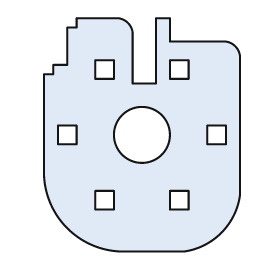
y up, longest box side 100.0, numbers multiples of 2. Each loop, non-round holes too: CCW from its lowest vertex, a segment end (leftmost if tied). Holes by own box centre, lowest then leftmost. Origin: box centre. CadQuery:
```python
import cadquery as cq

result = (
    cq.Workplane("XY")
    .moveTo(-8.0, -50.0)
    .lineTo(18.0, -50.0)
    .threePointArc((34.0, -42.0), (42.0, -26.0))
    .lineTo(42.0, 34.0)
    .threePointArc((40.0, 38.0), (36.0, 40.0))
    .lineTo(12.0, 40.0)
    .lineTo(12.0, 50.0)
    .lineTo(6.0, 50.0)
    .lineTo(6.0, 22.0)
    .lineTo(-4.0, 22.0)
    .lineTo(-4.0, 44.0)
    .threePointArc((-6.0, 48.0), (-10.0, 50.0))
    .lineTo(-28.0, 50.0)
    .lineTo(-28.0, 46.0)
    .lineTo(-32.0, 46.0)
    .lineTo(-32.0, 30.0)
    .lineTo(-38.0, 30.0)
    .lineTo(-38.0, 26.0)
    .lineTo(-42.0, 26.0)
    .lineTo(-42.0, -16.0)
    .threePointArc((-32.0, -40.0), (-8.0, -50.0))
    .close()
    .moveTo(-20.0, -32.0)
    .lineTo(-12.0, -32.0)
    .lineTo(-12.0, -24.0)
    .lineTo(-20.0, -24.0)
    .close()
    .moveTo(12.0, -32.0)
    .lineTo(20.0, -32.0)
    .lineTo(20.0, -24.0)
    .lineTo(12.0, -24.0)
    .close()
    .moveTo(-36.0, -4.0)
    .lineTo(-28.0, -4.0)
    .lineTo(-28.0, 4.0)
    .lineTo(-36.0, 4.0)
    .close()
    .moveTo(0.0, 0.0)
    .circle(12.0)
    .moveTo(28.0, -4.0)
    .lineTo(36.0, -4.0)
    .lineTo(36.0, 4.0)
    .lineTo(28.0, 4.0)
    .close()
    .moveTo(-20.0, 24.0)
    .lineTo(-12.0, 24.0)
    .lineTo(-12.0, 32.0)
    .lineTo(-20.0, 32.0)
    .close()
    .moveTo(12.0, 24.0)
    .lineTo(20.0, 24.0)
    .lineTo(20.0, 32.0)
    .lineTo(12.0, 32.0)
    .close()
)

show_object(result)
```